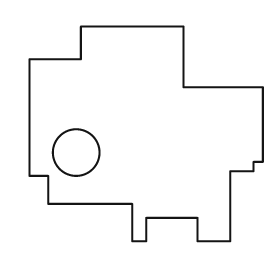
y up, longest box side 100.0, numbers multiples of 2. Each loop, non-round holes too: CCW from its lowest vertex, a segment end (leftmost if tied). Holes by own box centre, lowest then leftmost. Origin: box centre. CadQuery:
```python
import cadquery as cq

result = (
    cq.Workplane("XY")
    .moveTo(-6.0, -46.0)
    .lineTo(0.0, -46.0)
    .lineTo(0.0, -36.0)
    .lineTo(22.0, -36.0)
    .lineTo(22.0, -46.0)
    .lineTo(36.0, -46.0)
    .lineTo(36.0, -16.0)
    .lineTo(46.0, -16.0)
    .lineTo(46.0, -12.0)
    .lineTo(50.0, -12.0)
    .lineTo(50.0, 20.0)
    .lineTo(16.0, 20.0)
    .lineTo(16.0, 46.0)
    .lineTo(-28.0, 46.0)
    .lineTo(-28.0, 32.0)
    .lineTo(-50.0, 32.0)
    .lineTo(-50.0, -18.0)
    .lineTo(-42.0, -18.0)
    .lineTo(-42.0, -30.0)
    .lineTo(-6.0, -30.0)
    .close()
    .moveTo(-30.0, -8.0)
    .circle(10.0)
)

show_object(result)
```